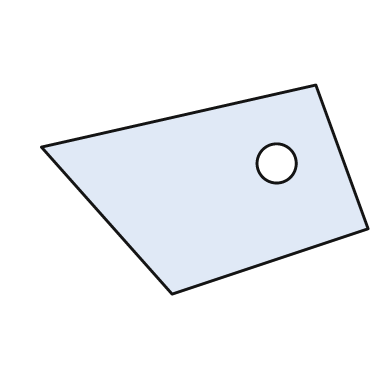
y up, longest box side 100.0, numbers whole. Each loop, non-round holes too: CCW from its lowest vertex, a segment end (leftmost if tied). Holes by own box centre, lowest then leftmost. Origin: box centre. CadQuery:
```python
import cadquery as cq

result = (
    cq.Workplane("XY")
    .moveTo(-10.0, -32.0)
    .lineTo(50.0, -12.0)
    .lineTo(34.0, 32.0)
    .lineTo(-50.0, 13.0)
    .close()
    .moveTo(22.0, 8.0)
    .circle(6.0)
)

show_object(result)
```